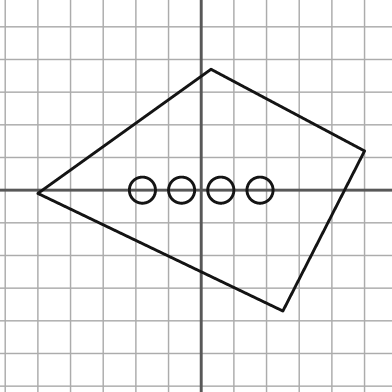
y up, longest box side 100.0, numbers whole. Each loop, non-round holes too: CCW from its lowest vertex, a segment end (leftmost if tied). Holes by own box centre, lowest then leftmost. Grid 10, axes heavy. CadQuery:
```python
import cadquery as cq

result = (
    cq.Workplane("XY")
    .moveTo(25.0, -37.0)
    .lineTo(50.0, 12.0)
    .lineTo(3.0, 37.0)
    .lineTo(-50.0, -1.0)
    .close()
    .moveTo(-18.0, 0.0)
    .circle(4.0)
    .moveTo(-6.0, 0.0)
    .circle(4.0)
    .moveTo(6.0, 0.0)
    .circle(4.0)
    .moveTo(18.0, 0.0)
    .circle(4.0)
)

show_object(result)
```